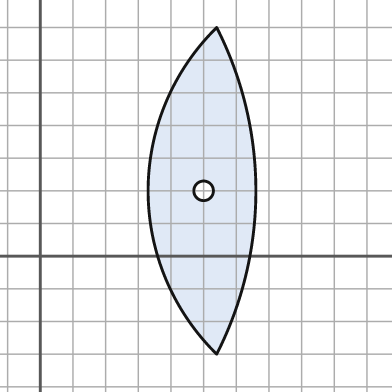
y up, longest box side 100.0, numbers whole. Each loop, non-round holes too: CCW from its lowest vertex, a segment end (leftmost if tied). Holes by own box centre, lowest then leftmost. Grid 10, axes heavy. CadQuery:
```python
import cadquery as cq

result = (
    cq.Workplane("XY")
    .moveTo(54.0, -30.0)
    .threePointArc((66.0, 20.0), (54.0, 70.0))
    .threePointArc((33.0, 20.0), (54.0, -30.0))
    .close()
    .moveTo(50.0, 20.0)
    .circle(3.0)
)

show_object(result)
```